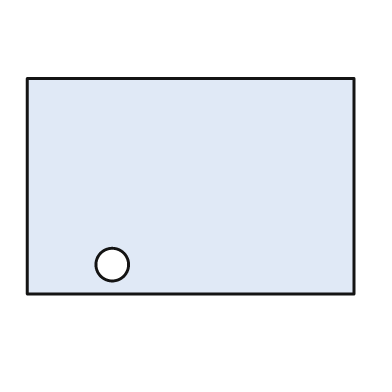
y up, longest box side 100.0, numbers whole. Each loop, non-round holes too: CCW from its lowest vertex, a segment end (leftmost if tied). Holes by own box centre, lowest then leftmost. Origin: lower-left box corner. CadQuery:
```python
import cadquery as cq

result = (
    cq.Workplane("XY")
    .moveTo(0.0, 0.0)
    .lineTo(100.0, 0.0)
    .lineTo(100.0, 66.0)
    .lineTo(0.0, 66.0)
    .close()
    .moveTo(26.0, 9.0)
    .circle(5.0)
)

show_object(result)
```